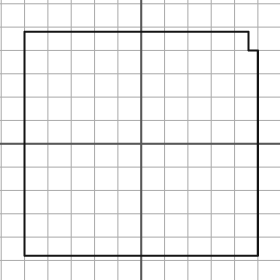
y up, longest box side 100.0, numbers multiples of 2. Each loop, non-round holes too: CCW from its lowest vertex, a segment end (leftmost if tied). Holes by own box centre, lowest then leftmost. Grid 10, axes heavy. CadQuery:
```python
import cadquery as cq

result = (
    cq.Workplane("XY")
    .moveTo(-50.0, -48.0)
    .lineTo(50.0, -48.0)
    .lineTo(50.0, 40.0)
    .lineTo(46.0, 40.0)
    .lineTo(46.0, 48.0)
    .lineTo(-50.0, 48.0)
    .close()
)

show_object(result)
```